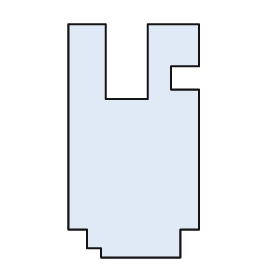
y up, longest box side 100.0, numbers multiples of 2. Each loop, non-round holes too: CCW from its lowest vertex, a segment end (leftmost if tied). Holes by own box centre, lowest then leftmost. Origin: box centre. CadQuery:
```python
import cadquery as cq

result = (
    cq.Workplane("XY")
    .moveTo(-14.0, -50.0)
    .lineTo(20.0, -50.0)
    .lineTo(20.0, -38.0)
    .lineTo(28.0, -38.0)
    .lineTo(28.0, 22.0)
    .lineTo(16.0, 22.0)
    .lineTo(16.0, 32.0)
    .lineTo(28.0, 32.0)
    .lineTo(28.0, 50.0)
    .lineTo(6.0, 50.0)
    .lineTo(6.0, 18.0)
    .lineTo(-12.0, 18.0)
    .lineTo(-12.0, 50.0)
    .lineTo(-28.0, 50.0)
    .lineTo(-28.0, -38.0)
    .lineTo(-20.0, -38.0)
    .lineTo(-20.0, -46.0)
    .lineTo(-14.0, -46.0)
    .close()
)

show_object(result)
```